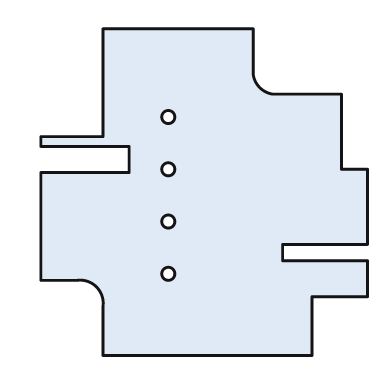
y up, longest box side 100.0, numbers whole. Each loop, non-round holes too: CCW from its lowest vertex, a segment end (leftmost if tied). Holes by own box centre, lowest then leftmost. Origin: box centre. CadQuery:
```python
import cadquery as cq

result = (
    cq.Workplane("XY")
    .moveTo(-31.0, -50.0)
    .lineTo(33.0, -50.0)
    .lineTo(33.0, -32.0)
    .lineTo(50.0, -32.0)
    .lineTo(50.0, -21.0)
    .lineTo(24.0, -21.0)
    .lineTo(24.0, -16.0)
    .lineTo(50.0, -16.0)
    .lineTo(50.0, 7.0)
    .lineTo(42.0, 7.0)
    .lineTo(42.0, 30.0)
    .lineTo(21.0, 30.0)
    .threePointArc((17.0, 32.0), (15.0, 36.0))
    .lineTo(15.0, 50.0)
    .lineTo(-31.0, 50.0)
    .lineTo(-31.0, 17.0)
    .lineTo(-50.0, 17.0)
    .lineTo(-50.0, 14.0)
    .lineTo(-23.0, 14.0)
    .lineTo(-23.0, 6.0)
    .lineTo(-50.0, 6.0)
    .lineTo(-50.0, -27.0)
    .lineTo(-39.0, -27.0)
    .threePointArc((-33.0, -29.0), (-31.0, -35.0))
    .close()
    .moveTo(-11.0, -25.0)
    .circle(2.0)
    .moveTo(-11.0, -9.0)
    .circle(2.0)
    .moveTo(-11.0, 7.0)
    .circle(2.0)
    .moveTo(-11.0, 23.0)
    .circle(2.0)
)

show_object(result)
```